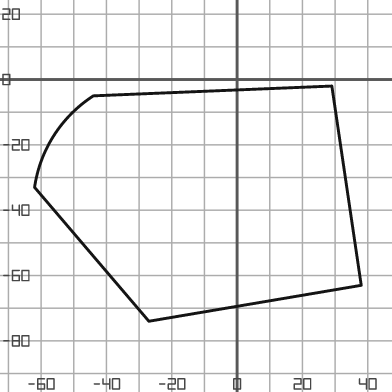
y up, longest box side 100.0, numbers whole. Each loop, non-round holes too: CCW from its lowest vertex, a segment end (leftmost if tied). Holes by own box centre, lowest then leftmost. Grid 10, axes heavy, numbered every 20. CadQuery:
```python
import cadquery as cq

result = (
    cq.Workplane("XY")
    .moveTo(-27.0, -74.0)
    .lineTo(38.0, -63.0)
    .lineTo(29.0, -2.0)
    .lineTo(-44.0, -5.0)
    .threePointArc((-56.0, -17.0), (-62.0, -33.0))
    .close()
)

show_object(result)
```